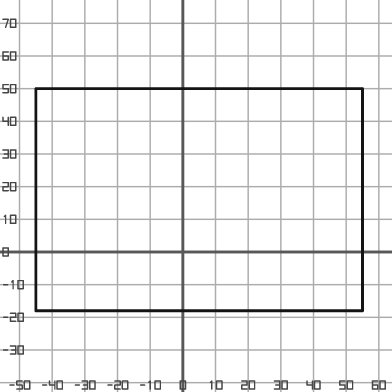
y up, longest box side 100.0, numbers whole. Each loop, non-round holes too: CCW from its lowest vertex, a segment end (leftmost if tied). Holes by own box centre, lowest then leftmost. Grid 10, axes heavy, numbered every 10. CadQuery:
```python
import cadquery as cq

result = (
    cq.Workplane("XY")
    .moveTo(-45.0, -18.0)
    .lineTo(55.0, -18.0)
    .lineTo(55.0, 50.0)
    .lineTo(-45.0, 50.0)
    .close()
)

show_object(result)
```